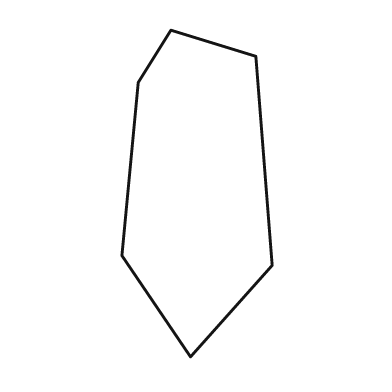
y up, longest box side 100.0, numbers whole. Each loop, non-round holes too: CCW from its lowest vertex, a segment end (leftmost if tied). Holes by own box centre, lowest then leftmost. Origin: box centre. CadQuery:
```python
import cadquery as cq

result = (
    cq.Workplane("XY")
    .moveTo(-2.0, -50.0)
    .lineTo(23.0, -22.0)
    .lineTo(18.0, 42.0)
    .lineTo(-8.0, 50.0)
    .lineTo(-18.0, 34.0)
    .lineTo(-23.0, -19.0)
    .close()
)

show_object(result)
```